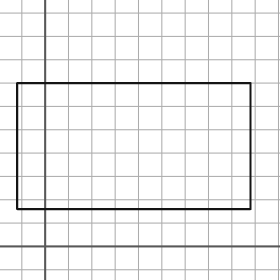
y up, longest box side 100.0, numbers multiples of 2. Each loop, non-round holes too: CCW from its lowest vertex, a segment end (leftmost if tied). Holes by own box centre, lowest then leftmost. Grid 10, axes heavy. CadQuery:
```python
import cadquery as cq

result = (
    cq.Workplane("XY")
    .moveTo(-12.0, 16.0)
    .lineTo(88.0, 16.0)
    .lineTo(88.0, 70.0)
    .lineTo(-12.0, 70.0)
    .close()
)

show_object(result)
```